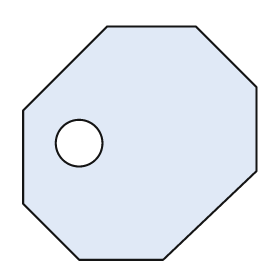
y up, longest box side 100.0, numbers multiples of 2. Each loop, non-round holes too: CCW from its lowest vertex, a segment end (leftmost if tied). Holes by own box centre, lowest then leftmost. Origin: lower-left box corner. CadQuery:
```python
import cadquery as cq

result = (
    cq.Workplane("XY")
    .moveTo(24.0, 0.0)
    .lineTo(60.0, 0.0)
    .lineTo(100.0, 38.0)
    .lineTo(100.0, 74.0)
    .lineTo(74.0, 100.0)
    .lineTo(36.0, 100.0)
    .lineTo(0.0, 64.0)
    .lineTo(0.0, 24.0)
    .close()
    .moveTo(24.0, 50.0)
    .circle(10.0)
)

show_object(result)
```